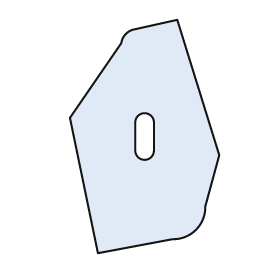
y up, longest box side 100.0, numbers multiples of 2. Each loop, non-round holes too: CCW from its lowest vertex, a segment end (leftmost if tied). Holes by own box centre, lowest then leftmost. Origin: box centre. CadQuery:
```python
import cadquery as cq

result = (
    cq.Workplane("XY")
    .moveTo(-20.0, -50.0)
    .lineTo(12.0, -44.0)
    .threePointArc((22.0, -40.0), (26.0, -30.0))
    .lineTo(32.0, -8.0)
    .lineTo(14.0, 50.0)
    .lineTo(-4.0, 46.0)
    .threePointArc((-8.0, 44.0), (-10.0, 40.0))
    .lineTo(-32.0, 8.0)
    .close()
    .moveTo(-4.0, -6.0)
    .threePointArc((0.0, -10.0), (4.0, -6.0))
    .lineTo(4.0, 6.0)
    .threePointArc((0.0, 10.0), (-4.0, 6.0))
    .close()
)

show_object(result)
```